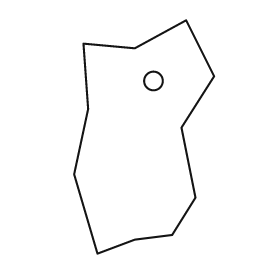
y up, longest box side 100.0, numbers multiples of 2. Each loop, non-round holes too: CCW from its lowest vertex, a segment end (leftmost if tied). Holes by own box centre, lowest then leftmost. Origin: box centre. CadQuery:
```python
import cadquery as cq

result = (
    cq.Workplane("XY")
    .moveTo(-20.0, -50.0)
    .lineTo(-4.0, -44.0)
    .lineTo(12.0, -42.0)
    .lineTo(22.0, -26.0)
    .lineTo(16.0, 4.0)
    .lineTo(30.0, 26.0)
    .lineTo(18.0, 50.0)
    .lineTo(-4.0, 38.0)
    .lineTo(-26.0, 40.0)
    .lineTo(-24.0, 12.0)
    .lineTo(-30.0, -16.0)
    .close()
    .moveTo(4.0, 24.0)
    .circle(4.0)
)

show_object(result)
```